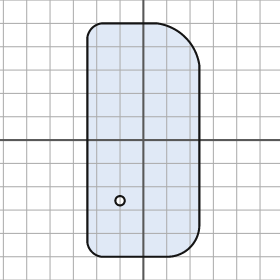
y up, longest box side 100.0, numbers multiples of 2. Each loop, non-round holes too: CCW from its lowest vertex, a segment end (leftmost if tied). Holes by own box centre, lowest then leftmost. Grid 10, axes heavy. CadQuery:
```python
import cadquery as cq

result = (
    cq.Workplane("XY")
    .moveTo(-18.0, -50.0)
    .lineTo(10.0, -50.0)
    .threePointArc((20.0, -46.0), (24.0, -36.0))
    .lineTo(24.0, 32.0)
    .threePointArc((18.0, 44.0), (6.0, 50.0))
    .lineTo(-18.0, 50.0)
    .threePointArc((-22.0, 48.0), (-24.0, 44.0))
    .lineTo(-24.0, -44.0)
    .threePointArc((-22.0, -48.0), (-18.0, -50.0))
    .close()
    .moveTo(-10.0, -26.0)
    .circle(2.0)
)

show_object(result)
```